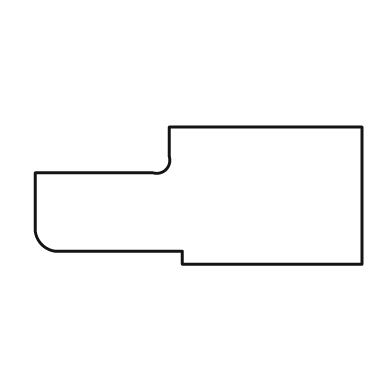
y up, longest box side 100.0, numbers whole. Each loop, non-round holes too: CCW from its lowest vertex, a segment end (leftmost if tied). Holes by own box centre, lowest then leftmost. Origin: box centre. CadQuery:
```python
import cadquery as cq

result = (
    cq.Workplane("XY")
    .moveTo(-5.0, -21.0)
    .lineTo(50.0, -21.0)
    .lineTo(50.0, 21.0)
    .lineTo(-9.0, 21.0)
    .lineTo(-9.0, 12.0)
    .threePointArc((-10.0, 8.0), (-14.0, 7.0))
    .lineTo(-50.0, 7.0)
    .lineTo(-50.0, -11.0)
    .threePointArc((-48.0, -15.0), (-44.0, -17.0))
    .lineTo(-5.0, -17.0)
    .close()
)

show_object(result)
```